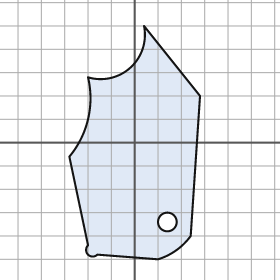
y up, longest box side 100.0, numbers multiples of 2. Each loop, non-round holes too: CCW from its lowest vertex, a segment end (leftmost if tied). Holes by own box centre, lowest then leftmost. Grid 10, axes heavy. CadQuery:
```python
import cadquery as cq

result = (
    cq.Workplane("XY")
    .moveTo(10.0, -50.0)
    .threePointArc((18.0, -46.0), (24.0, -40.0))
    .lineTo(28.0, 20.0)
    .lineTo(4.0, 50.0)
    .threePointArc((-2.0, 32.0), (-20.0, 28.0))
    .threePointArc((-20.0, 10.0), (-28.0, -6.0))
    .lineTo(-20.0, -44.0)
    .threePointArc((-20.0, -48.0), (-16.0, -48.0))
    .close()
    .moveTo(14.0, -34.0)
    .circle(4.0)
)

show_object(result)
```